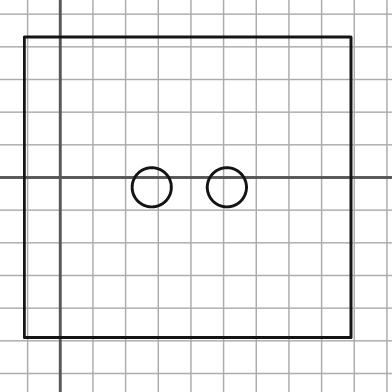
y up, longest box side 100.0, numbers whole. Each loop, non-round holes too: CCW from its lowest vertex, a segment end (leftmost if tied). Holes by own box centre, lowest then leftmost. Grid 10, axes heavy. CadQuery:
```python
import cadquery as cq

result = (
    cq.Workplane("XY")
    .moveTo(-11.0, -49.0)
    .lineTo(89.0, -49.0)
    .lineTo(89.0, 43.0)
    .lineTo(-11.0, 43.0)
    .close()
    .moveTo(28.0, -3.0)
    .circle(6.0)
    .moveTo(51.0, -3.0)
    .circle(6.0)
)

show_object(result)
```